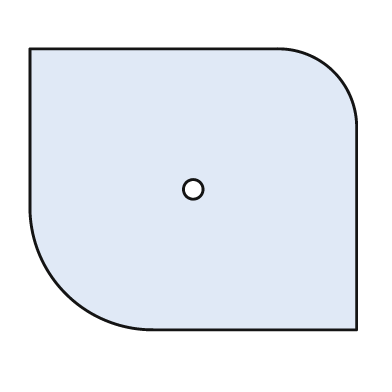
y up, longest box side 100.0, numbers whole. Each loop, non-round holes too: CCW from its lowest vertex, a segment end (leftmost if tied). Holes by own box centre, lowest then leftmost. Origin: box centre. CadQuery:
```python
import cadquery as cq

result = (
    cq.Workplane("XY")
    .moveTo(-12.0, -43.0)
    .lineTo(50.0, -43.0)
    .lineTo(50.0, 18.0)
    .threePointArc((43.0, 36.0), (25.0, 43.0))
    .lineTo(-50.0, 43.0)
    .lineTo(-50.0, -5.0)
    .threePointArc((-39.0, -32.0), (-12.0, -43.0))
    .close()
    .moveTo(0.0, 0.0)
    .circle(3.0)
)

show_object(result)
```